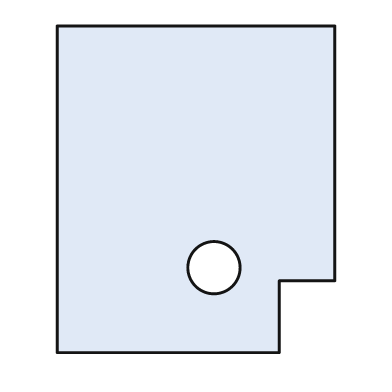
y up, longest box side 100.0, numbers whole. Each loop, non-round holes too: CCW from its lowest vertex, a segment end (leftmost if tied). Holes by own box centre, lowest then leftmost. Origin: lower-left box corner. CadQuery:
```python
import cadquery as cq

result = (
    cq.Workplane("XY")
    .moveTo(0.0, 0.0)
    .lineTo(68.0, 0.0)
    .lineTo(68.0, 22.0)
    .lineTo(85.0, 22.0)
    .lineTo(85.0, 100.0)
    .lineTo(0.0, 100.0)
    .close()
    .moveTo(48.0, 26.0)
    .circle(8.0)
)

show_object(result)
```